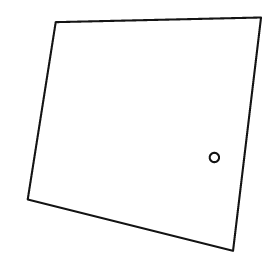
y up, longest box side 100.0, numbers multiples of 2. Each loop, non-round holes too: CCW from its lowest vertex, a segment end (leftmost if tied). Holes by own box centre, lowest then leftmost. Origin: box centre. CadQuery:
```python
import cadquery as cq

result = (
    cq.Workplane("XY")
    .moveTo(38.0, -50.0)
    .lineTo(50.0, 50.0)
    .lineTo(-38.0, 48.0)
    .lineTo(-50.0, -28.0)
    .close()
    .moveTo(30.0, -10.0)
    .circle(2.0)
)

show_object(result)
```